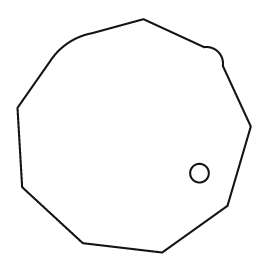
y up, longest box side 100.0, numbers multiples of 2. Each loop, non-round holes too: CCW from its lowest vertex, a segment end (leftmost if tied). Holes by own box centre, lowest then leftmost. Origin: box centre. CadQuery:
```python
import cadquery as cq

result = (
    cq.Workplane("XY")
    .moveTo(12.0, -50.0)
    .lineTo(40.0, -30.0)
    .lineTo(50.0, 4.0)
    .lineTo(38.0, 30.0)
    .threePointArc((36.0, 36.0), (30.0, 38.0))
    .lineTo(4.0, 50.0)
    .lineTo(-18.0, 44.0)
    .threePointArc((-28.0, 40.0), (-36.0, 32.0))
    .lineTo(-50.0, 12.0)
    .lineTo(-48.0, -22.0)
    .lineTo(-22.0, -46.0)
    .close()
    .moveTo(28.0, -16.0)
    .circle(4.0)
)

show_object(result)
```